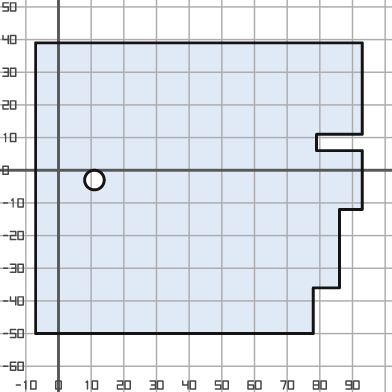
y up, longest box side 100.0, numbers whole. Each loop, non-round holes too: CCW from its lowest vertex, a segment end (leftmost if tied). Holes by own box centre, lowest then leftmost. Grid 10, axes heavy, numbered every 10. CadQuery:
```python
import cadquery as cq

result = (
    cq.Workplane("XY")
    .moveTo(-7.0, -50.0)
    .lineTo(78.0, -50.0)
    .lineTo(78.0, -36.0)
    .lineTo(86.0, -36.0)
    .lineTo(86.0, -12.0)
    .lineTo(93.0, -12.0)
    .lineTo(93.0, 6.0)
    .lineTo(79.0, 6.0)
    .lineTo(79.0, 11.0)
    .lineTo(93.0, 11.0)
    .lineTo(93.0, 39.0)
    .lineTo(-7.0, 39.0)
    .close()
    .moveTo(11.0, -3.0)
    .circle(3.0)
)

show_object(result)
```